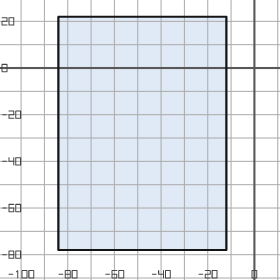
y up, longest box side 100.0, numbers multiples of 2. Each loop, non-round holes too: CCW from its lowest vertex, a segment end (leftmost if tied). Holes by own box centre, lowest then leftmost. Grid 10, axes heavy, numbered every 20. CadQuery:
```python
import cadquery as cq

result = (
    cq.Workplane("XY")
    .moveTo(-84.0, -78.0)
    .lineTo(-12.0, -78.0)
    .lineTo(-12.0, 22.0)
    .lineTo(-84.0, 22.0)
    .close()
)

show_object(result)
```